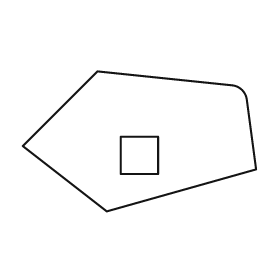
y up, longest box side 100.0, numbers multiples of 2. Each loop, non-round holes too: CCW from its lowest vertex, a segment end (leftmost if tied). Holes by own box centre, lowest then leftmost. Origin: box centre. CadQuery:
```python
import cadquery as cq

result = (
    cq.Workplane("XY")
    .moveTo(-14.0, -30.0)
    .lineTo(50.0, -12.0)
    .lineTo(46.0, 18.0)
    .threePointArc((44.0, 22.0), (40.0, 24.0))
    .lineTo(-18.0, 30.0)
    .lineTo(-50.0, -2.0)
    .close()
    .moveTo(-8.0, -14.0)
    .lineTo(8.0, -14.0)
    .lineTo(8.0, 2.0)
    .lineTo(-8.0, 2.0)
    .close()
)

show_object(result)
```